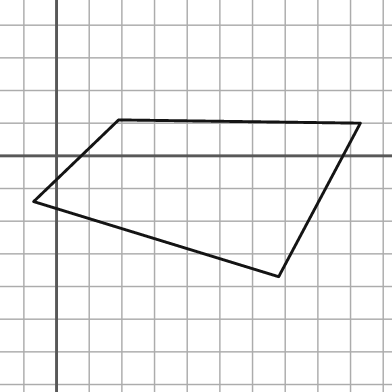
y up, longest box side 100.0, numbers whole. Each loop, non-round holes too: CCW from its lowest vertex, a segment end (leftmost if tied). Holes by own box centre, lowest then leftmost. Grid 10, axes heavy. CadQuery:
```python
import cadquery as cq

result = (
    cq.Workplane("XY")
    .moveTo(68.0, -37.0)
    .lineTo(93.0, 10.0)
    .lineTo(19.0, 11.0)
    .lineTo(-7.0, -14.0)
    .close()
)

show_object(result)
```